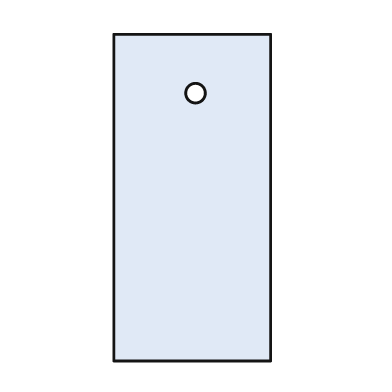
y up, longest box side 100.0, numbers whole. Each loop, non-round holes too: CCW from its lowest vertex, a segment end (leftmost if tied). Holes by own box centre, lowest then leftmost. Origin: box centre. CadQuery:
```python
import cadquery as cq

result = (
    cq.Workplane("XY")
    .moveTo(-24.0, -50.0)
    .lineTo(24.0, -50.0)
    .lineTo(24.0, 50.0)
    .lineTo(-24.0, 50.0)
    .close()
    .moveTo(1.0, 32.0)
    .circle(3.0)
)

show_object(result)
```